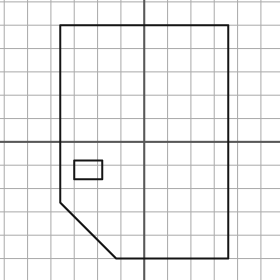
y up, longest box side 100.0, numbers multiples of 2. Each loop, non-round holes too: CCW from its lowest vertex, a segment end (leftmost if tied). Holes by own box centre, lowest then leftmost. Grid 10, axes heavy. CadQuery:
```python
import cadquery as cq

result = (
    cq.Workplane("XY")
    .moveTo(-12.0, -50.0)
    .lineTo(36.0, -50.0)
    .lineTo(36.0, 50.0)
    .lineTo(-36.0, 50.0)
    .lineTo(-36.0, -26.0)
    .close()
    .moveTo(-30.0, -16.0)
    .lineTo(-18.0, -16.0)
    .lineTo(-18.0, -8.0)
    .lineTo(-30.0, -8.0)
    .close()
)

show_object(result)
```